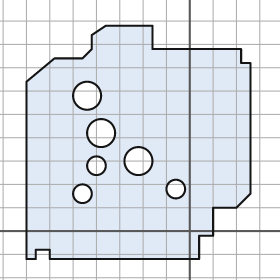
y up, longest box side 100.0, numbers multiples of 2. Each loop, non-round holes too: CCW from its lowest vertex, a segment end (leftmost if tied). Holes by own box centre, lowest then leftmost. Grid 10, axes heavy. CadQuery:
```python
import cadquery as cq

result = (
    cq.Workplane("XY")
    .moveTo(-70.0, -12.0)
    .lineTo(-66.0, -12.0)
    .lineTo(-66.0, -8.0)
    .lineTo(-60.0, -8.0)
    .lineTo(-60.0, -12.0)
    .lineTo(4.0, -12.0)
    .lineTo(4.0, -2.0)
    .lineTo(10.0, -2.0)
    .lineTo(10.0, 10.0)
    .lineTo(20.0, 10.0)
    .lineTo(26.0, 16.0)
    .lineTo(26.0, 72.0)
    .lineTo(22.0, 72.0)
    .lineTo(22.0, 78.0)
    .lineTo(-16.0, 78.0)
    .lineTo(-16.0, 88.0)
    .lineTo(-36.0, 88.0)
    .lineTo(-42.0, 84.0)
    .lineTo(-42.0, 78.0)
    .lineTo(-46.0, 74.0)
    .lineTo(-58.0, 74.0)
    .lineTo(-70.0, 64.0)
    .close()
    .moveTo(-46.0, 16.0)
    .circle(4.0)
    .moveTo(-6.0, 18.0)
    .circle(4.0)
    .moveTo(-40.0, 28.0)
    .circle(4.0)
    .moveTo(-22.0, 30.0)
    .circle(6.0)
    .moveTo(-38.0, 42.0)
    .circle(6.0)
    .moveTo(-44.0, 58.0)
    .circle(6.0)
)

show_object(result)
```